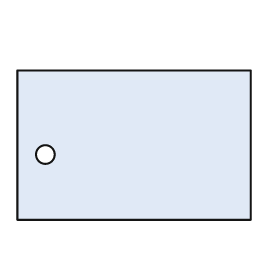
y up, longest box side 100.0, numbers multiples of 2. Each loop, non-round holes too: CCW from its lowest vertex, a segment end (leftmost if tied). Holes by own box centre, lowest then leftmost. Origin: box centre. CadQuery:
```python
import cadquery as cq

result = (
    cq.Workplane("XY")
    .moveTo(-50.0, -32.0)
    .lineTo(50.0, -32.0)
    .lineTo(50.0, 32.0)
    .lineTo(-50.0, 32.0)
    .close()
    .moveTo(-38.0, -4.0)
    .circle(4.0)
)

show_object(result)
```